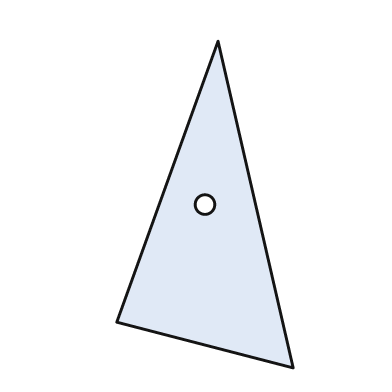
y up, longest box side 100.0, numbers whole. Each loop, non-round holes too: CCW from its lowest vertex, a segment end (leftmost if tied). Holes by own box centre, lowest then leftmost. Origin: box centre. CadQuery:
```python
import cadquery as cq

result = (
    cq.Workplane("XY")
    .moveTo(27.0, -50.0)
    .lineTo(4.0, 50.0)
    .lineTo(-27.0, -36.0)
    .close()
    .moveTo(0.0, 0.0)
    .circle(3.0)
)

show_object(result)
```